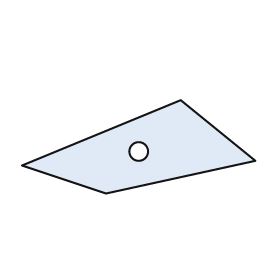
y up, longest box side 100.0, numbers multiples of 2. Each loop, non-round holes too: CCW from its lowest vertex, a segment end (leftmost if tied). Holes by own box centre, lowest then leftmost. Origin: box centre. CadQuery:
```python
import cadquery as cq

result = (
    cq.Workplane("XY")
    .moveTo(-14.0, -20.0)
    .lineTo(50.0, -6.0)
    .lineTo(18.0, 20.0)
    .lineTo(-50.0, -8.0)
    .close()
    .moveTo(0.0, -2.0)
    .circle(4.0)
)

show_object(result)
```